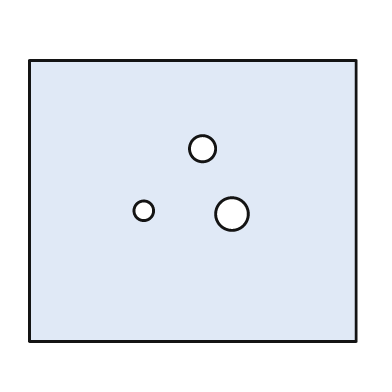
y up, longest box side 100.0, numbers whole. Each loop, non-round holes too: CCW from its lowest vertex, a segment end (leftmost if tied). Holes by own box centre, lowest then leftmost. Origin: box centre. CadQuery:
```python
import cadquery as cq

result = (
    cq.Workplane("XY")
    .moveTo(-50.0, -43.0)
    .lineTo(50.0, -43.0)
    .lineTo(50.0, 43.0)
    .lineTo(-50.0, 43.0)
    .close()
    .moveTo(12.0, -4.0)
    .circle(5.0)
    .moveTo(-15.0, -3.0)
    .circle(3.0)
    .moveTo(3.0, 16.0)
    .circle(4.0)
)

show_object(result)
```